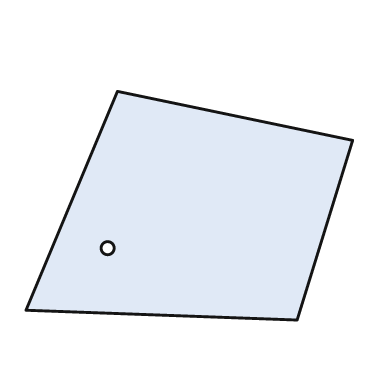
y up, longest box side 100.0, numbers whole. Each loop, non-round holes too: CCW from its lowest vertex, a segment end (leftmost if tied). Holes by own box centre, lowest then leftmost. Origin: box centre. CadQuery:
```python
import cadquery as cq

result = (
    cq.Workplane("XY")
    .moveTo(33.0, -35.0)
    .lineTo(50.0, 20.0)
    .lineTo(-22.0, 35.0)
    .lineTo(-50.0, -32.0)
    .close()
    .moveTo(-25.0, -13.0)
    .circle(2.0)
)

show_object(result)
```